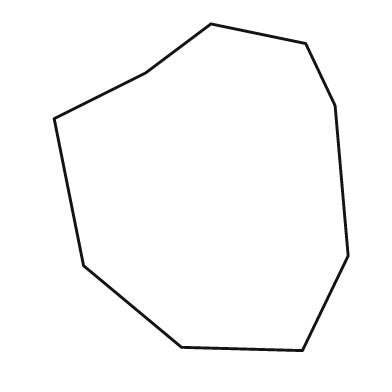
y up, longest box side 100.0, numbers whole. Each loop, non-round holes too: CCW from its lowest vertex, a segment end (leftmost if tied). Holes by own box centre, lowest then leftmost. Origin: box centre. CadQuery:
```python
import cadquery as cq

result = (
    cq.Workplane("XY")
    .moveTo(31.0, -50.0)
    .lineTo(45.0, -21.0)
    .lineTo(41.0, 25.0)
    .lineTo(32.0, 44.0)
    .lineTo(3.0, 50.0)
    .lineTo(-17.0, 35.0)
    .lineTo(-45.0, 21.0)
    .lineTo(-36.0, -24.0)
    .lineTo(-6.0, -49.0)
    .close()
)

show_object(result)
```